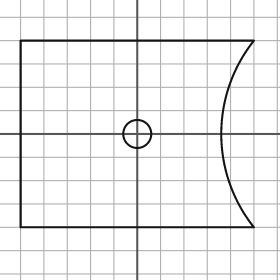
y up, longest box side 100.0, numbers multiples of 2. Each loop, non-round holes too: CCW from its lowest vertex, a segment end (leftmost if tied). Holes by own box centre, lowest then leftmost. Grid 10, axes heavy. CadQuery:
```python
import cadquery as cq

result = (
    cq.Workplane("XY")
    .moveTo(-50.0, -40.0)
    .lineTo(50.0, -40.0)
    .threePointArc((36.0, 0.0), (50.0, 40.0))
    .lineTo(-50.0, 40.0)
    .close()
    .moveTo(0.0, 0.0)
    .circle(6.0)
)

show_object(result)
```